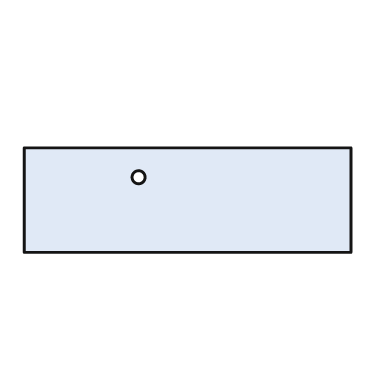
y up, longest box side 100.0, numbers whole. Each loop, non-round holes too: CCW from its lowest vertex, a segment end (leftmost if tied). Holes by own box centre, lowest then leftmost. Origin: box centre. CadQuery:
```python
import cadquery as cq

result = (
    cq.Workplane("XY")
    .moveTo(-50.0, -16.0)
    .lineTo(50.0, -16.0)
    .lineTo(50.0, 16.0)
    .lineTo(-50.0, 16.0)
    .close()
    .moveTo(-15.0, 7.0)
    .circle(2.0)
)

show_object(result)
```